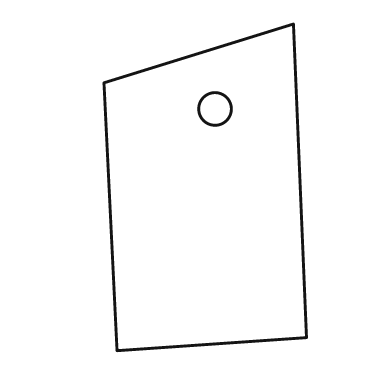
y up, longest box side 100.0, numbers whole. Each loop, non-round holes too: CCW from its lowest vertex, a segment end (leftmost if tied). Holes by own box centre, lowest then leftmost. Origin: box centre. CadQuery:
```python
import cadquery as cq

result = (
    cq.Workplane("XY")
    .moveTo(-27.0, -50.0)
    .lineTo(31.0, -46.0)
    .lineTo(27.0, 50.0)
    .lineTo(-31.0, 32.0)
    .close()
    .moveTo(3.0, 24.0)
    .circle(5.0)
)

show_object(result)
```